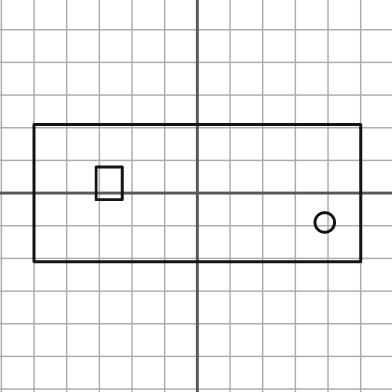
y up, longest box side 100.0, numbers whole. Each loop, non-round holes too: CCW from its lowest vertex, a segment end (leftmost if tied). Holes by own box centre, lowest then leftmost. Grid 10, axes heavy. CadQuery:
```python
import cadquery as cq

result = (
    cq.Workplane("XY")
    .moveTo(-50.0, -21.0)
    .lineTo(50.0, -21.0)
    .lineTo(50.0, 21.0)
    .lineTo(-50.0, 21.0)
    .close()
    .moveTo(39.0, -9.0)
    .circle(3.0)
    .moveTo(-31.0, -2.0)
    .lineTo(-23.0, -2.0)
    .lineTo(-23.0, 8.0)
    .lineTo(-31.0, 8.0)
    .close()
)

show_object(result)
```